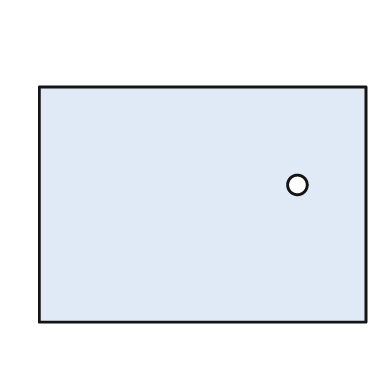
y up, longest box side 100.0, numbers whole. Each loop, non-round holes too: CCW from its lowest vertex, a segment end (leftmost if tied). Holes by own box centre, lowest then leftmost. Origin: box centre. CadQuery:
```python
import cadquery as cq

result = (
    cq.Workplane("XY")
    .moveTo(-50.0, -36.0)
    .lineTo(50.0, -36.0)
    .lineTo(50.0, 36.0)
    .lineTo(-50.0, 36.0)
    .close()
    .moveTo(29.0, 6.0)
    .circle(3.0)
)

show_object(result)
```